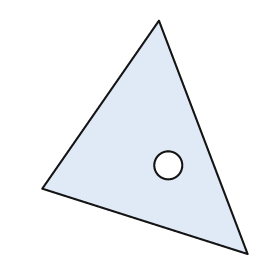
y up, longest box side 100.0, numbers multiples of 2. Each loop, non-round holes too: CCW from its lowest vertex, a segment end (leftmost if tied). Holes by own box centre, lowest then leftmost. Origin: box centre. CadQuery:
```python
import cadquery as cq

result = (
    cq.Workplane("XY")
    .moveTo(44.0, -50.0)
    .lineTo(6.0, 50.0)
    .lineTo(-44.0, -22.0)
    .close()
    .moveTo(10.0, -12.0)
    .circle(6.0)
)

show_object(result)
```